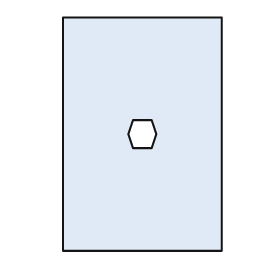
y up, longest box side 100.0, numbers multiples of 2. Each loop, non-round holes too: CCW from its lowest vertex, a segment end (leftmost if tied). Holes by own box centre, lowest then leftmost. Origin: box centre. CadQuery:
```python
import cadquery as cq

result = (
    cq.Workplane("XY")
    .moveTo(-34.0, -50.0)
    .lineTo(34.0, -50.0)
    .lineTo(34.0, 50.0)
    .lineTo(-34.0, 50.0)
    .close()
    .moveTo(-4.0, -6.0)
    .lineTo(4.0, -6.0)
    .lineTo(6.0, 0.0)
    .lineTo(4.0, 6.0)
    .lineTo(-4.0, 6.0)
    .lineTo(-6.0, 0.0)
    .close()
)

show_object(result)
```